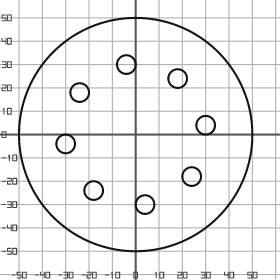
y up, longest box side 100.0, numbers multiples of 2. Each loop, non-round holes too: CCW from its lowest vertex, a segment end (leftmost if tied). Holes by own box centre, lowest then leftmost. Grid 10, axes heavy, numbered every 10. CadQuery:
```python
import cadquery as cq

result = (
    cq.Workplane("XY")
    .moveTo(0.0, 0.0)
    .circle(50.0)
    .moveTo(4.0, -30.0)
    .circle(4.0)
    .moveTo(-18.0, -24.0)
    .circle(4.0)
    .moveTo(24.0, -18.0)
    .circle(4.0)
    .moveTo(-30.0, -4.0)
    .circle(4.0)
    .moveTo(30.0, 4.0)
    .circle(4.0)
    .moveTo(-24.0, 18.0)
    .circle(4.0)
    .moveTo(18.0, 24.0)
    .circle(4.0)
    .moveTo(-4.0, 30.0)
    .circle(4.0)
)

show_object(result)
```